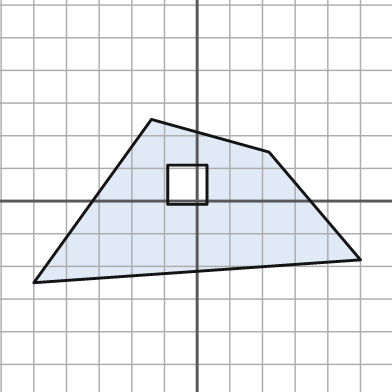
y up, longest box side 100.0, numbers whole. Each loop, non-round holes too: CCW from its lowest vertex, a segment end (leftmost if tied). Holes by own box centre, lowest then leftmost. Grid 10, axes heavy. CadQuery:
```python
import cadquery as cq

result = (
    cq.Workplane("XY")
    .moveTo(-50.0, -25.0)
    .lineTo(50.0, -18.0)
    .lineTo(22.0, 15.0)
    .lineTo(-14.0, 25.0)
    .close()
    .moveTo(-9.0, -1.0)
    .lineTo(3.0, -1.0)
    .lineTo(3.0, 11.0)
    .lineTo(-9.0, 11.0)
    .close()
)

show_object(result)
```